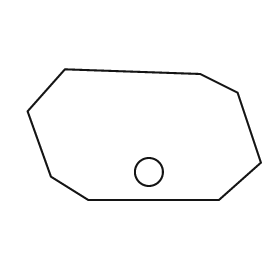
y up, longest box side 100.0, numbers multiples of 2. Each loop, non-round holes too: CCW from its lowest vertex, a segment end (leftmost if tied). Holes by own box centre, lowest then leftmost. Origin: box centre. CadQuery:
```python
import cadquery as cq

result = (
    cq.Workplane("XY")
    .moveTo(-24.0, -28.0)
    .lineTo(32.0, -28.0)
    .lineTo(50.0, -12.0)
    .lineTo(40.0, 18.0)
    .lineTo(24.0, 26.0)
    .lineTo(-34.0, 28.0)
    .lineTo(-50.0, 10.0)
    .lineTo(-40.0, -18.0)
    .close()
    .moveTo(2.0, -16.0)
    .circle(6.0)
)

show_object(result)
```